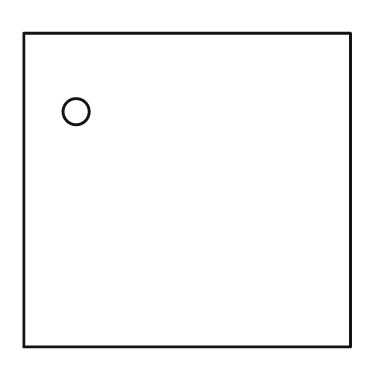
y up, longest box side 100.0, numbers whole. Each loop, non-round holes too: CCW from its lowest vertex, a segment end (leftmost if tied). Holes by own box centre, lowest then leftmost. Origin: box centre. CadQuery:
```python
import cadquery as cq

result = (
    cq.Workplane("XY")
    .moveTo(-50.0, -48.0)
    .lineTo(50.0, -48.0)
    .lineTo(50.0, 48.0)
    .lineTo(-50.0, 48.0)
    .close()
    .moveTo(-34.0, 24.0)
    .circle(4.0)
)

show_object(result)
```